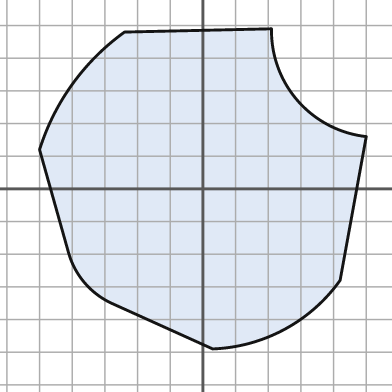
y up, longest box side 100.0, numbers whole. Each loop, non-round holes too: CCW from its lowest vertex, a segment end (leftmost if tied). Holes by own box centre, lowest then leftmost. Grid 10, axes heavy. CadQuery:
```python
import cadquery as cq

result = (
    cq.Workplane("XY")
    .moveTo(3.0, -49.0)
    .threePointArc((25.0, -43.0), (42.0, -28.0))
    .lineTo(50.0, 16.0)
    .threePointArc((29.0, 27.0), (21.0, 49.0))
    .lineTo(-24.0, 48.0)
    .threePointArc((-40.0, 32.0), (-50.0, 12.0))
    .lineTo(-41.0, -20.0)
    .threePointArc((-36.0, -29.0), (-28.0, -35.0))
    .close()
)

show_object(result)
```